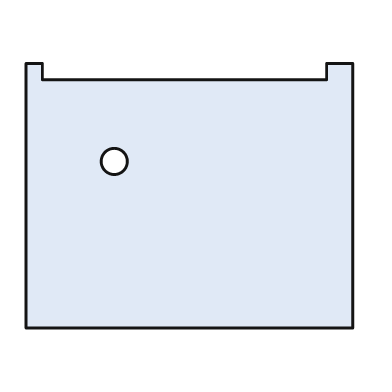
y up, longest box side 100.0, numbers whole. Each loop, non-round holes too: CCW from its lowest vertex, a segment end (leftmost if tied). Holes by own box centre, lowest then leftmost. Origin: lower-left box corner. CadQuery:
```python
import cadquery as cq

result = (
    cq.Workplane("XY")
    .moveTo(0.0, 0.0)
    .lineTo(100.0, 0.0)
    .lineTo(100.0, 81.0)
    .lineTo(92.0, 81.0)
    .lineTo(92.0, 76.0)
    .lineTo(5.0, 76.0)
    .lineTo(5.0, 81.0)
    .lineTo(0.0, 81.0)
    .close()
    .moveTo(27.0, 51.0)
    .circle(4.0)
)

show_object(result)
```